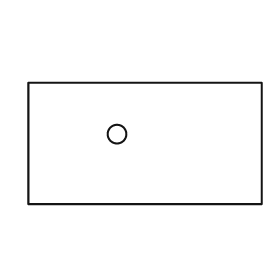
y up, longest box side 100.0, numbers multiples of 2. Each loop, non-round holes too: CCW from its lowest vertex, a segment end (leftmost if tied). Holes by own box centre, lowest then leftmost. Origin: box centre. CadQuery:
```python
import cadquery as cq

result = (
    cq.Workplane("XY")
    .moveTo(-50.0, -26.0)
    .lineTo(50.0, -26.0)
    .lineTo(50.0, 26.0)
    .lineTo(-50.0, 26.0)
    .close()
    .moveTo(-12.0, 4.0)
    .circle(4.0)
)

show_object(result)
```